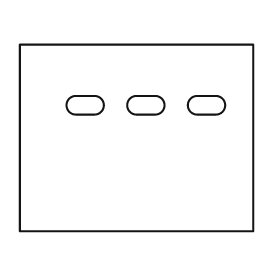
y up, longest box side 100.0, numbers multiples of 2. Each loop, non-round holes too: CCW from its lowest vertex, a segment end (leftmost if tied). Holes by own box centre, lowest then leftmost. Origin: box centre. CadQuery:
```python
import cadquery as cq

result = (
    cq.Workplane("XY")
    .moveTo(-50.0, -40.0)
    .lineTo(50.0, -40.0)
    .lineTo(50.0, 40.0)
    .lineTo(-50.0, 40.0)
    .close()
    .moveTo(-26.0, 10.0)
    .lineTo(-18.0, 10.0)
    .threePointArc((-14.0, 14.0), (-18.0, 18.0))
    .lineTo(-26.0, 18.0)
    .threePointArc((-30.0, 14.0), (-26.0, 10.0))
    .close()
    .moveTo(0.0, 10.0)
    .lineTo(8.0, 10.0)
    .threePointArc((12.0, 14.0), (8.0, 18.0))
    .lineTo(0.0, 18.0)
    .threePointArc((-4.0, 14.0), (0.0, 10.0))
    .close()
    .moveTo(26.0, 10.0)
    .lineTo(34.0, 10.0)
    .threePointArc((38.0, 14.0), (34.0, 18.0))
    .lineTo(26.0, 18.0)
    .threePointArc((22.0, 14.0), (26.0, 10.0))
    .close()
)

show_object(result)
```